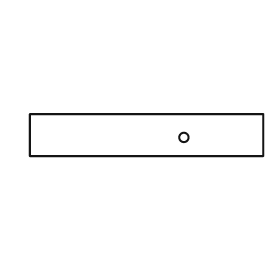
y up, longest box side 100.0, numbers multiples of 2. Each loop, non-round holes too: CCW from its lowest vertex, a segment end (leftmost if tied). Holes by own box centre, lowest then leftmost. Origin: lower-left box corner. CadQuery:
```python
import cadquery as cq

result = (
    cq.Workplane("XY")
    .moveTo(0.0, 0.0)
    .lineTo(100.0, 0.0)
    .lineTo(100.0, 18.0)
    .lineTo(0.0, 18.0)
    .close()
    .moveTo(66.0, 8.0)
    .circle(2.0)
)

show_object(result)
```